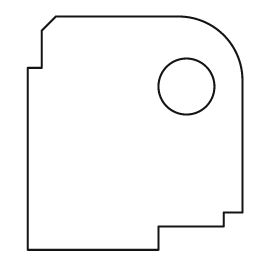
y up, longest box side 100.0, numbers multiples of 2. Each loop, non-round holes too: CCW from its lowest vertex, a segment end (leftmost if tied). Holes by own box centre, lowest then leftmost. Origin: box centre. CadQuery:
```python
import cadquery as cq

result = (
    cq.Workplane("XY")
    .moveTo(-46.0, -50.0)
    .lineTo(10.0, -50.0)
    .lineTo(10.0, -40.0)
    .lineTo(38.0, -40.0)
    .lineTo(38.0, -34.0)
    .lineTo(46.0, -34.0)
    .lineTo(46.0, 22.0)
    .threePointArc((38.0, 42.0), (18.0, 50.0))
    .lineTo(-34.0, 50.0)
    .lineTo(-40.0, 44.0)
    .lineTo(-40.0, 28.0)
    .lineTo(-46.0, 28.0)
    .close()
    .moveTo(22.0, 20.0)
    .circle(12.0)
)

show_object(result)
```